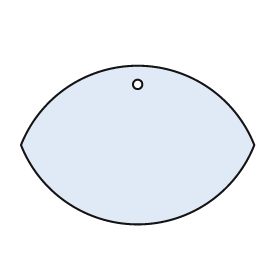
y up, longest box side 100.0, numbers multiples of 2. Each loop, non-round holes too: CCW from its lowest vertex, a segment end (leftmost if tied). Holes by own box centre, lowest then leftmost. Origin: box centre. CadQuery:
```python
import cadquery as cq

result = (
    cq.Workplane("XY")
    .moveTo(-50.0, 0.0)
    .threePointArc((0.0, -34.0), (50.0, 0.0))
    .threePointArc((0.0, 34.0), (-50.0, 0.0))
    .close()
    .moveTo(0.0, 26.0)
    .circle(2.0)
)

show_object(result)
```